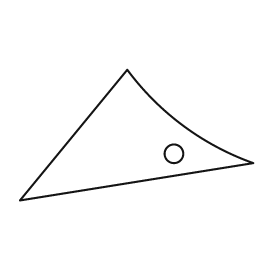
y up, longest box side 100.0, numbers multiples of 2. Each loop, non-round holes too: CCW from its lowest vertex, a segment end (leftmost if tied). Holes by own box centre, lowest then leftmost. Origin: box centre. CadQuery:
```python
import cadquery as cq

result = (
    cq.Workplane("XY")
    .moveTo(-50.0, -28.0)
    .lineTo(50.0, -12.0)
    .threePointArc((20.0, 4.0), (-4.0, 28.0))
    .close()
    .moveTo(16.0, -8.0)
    .circle(4.0)
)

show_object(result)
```